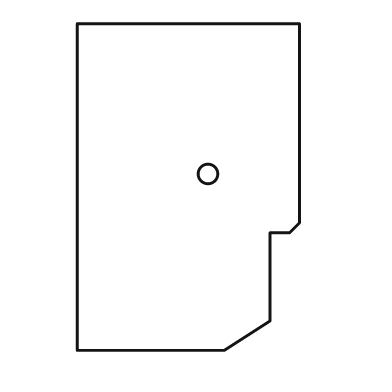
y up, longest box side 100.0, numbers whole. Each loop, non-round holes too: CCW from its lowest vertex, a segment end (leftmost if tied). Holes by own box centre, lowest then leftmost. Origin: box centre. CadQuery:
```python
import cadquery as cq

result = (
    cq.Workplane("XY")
    .moveTo(-34.0, -50.0)
    .lineTo(11.0, -50.0)
    .lineTo(25.0, -41.0)
    .lineTo(25.0, -14.0)
    .lineTo(31.0, -14.0)
    .lineTo(34.0, -11.0)
    .lineTo(34.0, 50.0)
    .lineTo(-34.0, 50.0)
    .close()
    .moveTo(6.0, 4.0)
    .circle(3.0)
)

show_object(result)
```